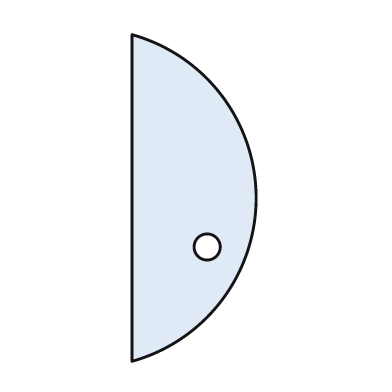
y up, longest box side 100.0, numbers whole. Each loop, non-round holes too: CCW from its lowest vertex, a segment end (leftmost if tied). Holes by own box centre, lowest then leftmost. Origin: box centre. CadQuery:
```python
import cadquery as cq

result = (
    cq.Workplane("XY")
    .moveTo(-19.0, -50.0)
    .threePointArc((19.0, 0.0), (-19.0, 50.0))
    .close()
    .moveTo(4.0, -15.0)
    .circle(4.0)
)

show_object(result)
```